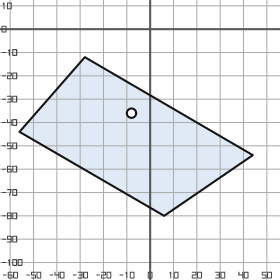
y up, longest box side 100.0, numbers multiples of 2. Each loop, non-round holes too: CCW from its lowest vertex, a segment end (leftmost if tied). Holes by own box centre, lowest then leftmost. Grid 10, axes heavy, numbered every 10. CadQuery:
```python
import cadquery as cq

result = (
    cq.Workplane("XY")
    .moveTo(6.0, -80.0)
    .lineTo(44.0, -54.0)
    .lineTo(-28.0, -12.0)
    .lineTo(-56.0, -44.0)
    .close()
    .moveTo(-8.0, -36.0)
    .circle(2.0)
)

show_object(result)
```